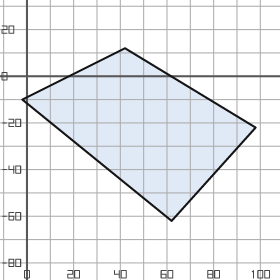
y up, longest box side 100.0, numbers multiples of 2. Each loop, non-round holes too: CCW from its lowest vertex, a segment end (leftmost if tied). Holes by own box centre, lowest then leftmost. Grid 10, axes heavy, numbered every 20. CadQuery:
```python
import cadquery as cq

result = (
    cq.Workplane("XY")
    .moveTo(62.0, -62.0)
    .lineTo(98.0, -22.0)
    .lineTo(42.0, 12.0)
    .lineTo(-2.0, -10.0)
    .close()
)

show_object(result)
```